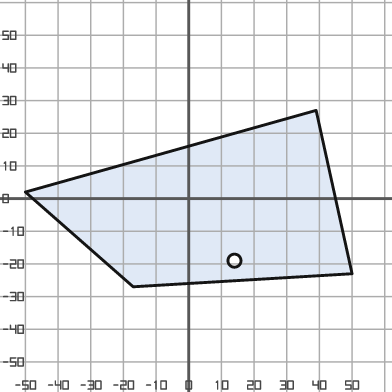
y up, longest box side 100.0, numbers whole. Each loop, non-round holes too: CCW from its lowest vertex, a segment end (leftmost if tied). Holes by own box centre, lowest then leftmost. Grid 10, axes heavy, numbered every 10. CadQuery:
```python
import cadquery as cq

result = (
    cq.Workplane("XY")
    .moveTo(-17.0, -27.0)
    .lineTo(50.0, -23.0)
    .lineTo(39.0, 27.0)
    .lineTo(-50.0, 2.0)
    .close()
    .moveTo(14.0, -19.0)
    .circle(2.0)
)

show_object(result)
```